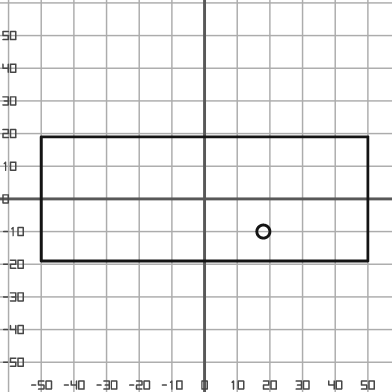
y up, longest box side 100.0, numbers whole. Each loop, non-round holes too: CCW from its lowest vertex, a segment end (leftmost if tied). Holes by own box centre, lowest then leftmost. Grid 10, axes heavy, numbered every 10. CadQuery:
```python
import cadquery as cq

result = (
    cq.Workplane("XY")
    .moveTo(-50.0, -19.0)
    .lineTo(50.0, -19.0)
    .lineTo(50.0, 19.0)
    .lineTo(-50.0, 19.0)
    .close()
    .moveTo(18.0, -10.0)
    .circle(2.0)
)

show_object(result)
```